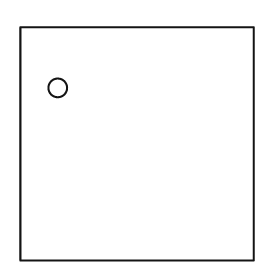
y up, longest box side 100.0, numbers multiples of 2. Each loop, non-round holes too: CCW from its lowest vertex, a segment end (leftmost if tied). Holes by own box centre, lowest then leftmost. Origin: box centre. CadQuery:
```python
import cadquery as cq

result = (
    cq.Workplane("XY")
    .moveTo(-50.0, -50.0)
    .lineTo(50.0, -50.0)
    .lineTo(50.0, 50.0)
    .lineTo(-50.0, 50.0)
    .close()
    .moveTo(-34.0, 24.0)
    .circle(4.0)
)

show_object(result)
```